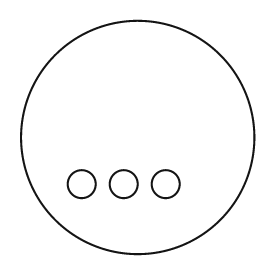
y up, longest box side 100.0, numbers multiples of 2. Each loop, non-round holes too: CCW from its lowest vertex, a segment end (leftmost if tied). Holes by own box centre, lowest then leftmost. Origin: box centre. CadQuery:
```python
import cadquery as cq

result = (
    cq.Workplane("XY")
    .moveTo(0.0, 0.0)
    .circle(50.0)
    .moveTo(-24.0, -20.0)
    .circle(6.0)
    .moveTo(-6.0, -20.0)
    .circle(6.0)
    .moveTo(12.0, -20.0)
    .circle(6.0)
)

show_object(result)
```